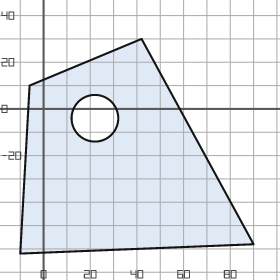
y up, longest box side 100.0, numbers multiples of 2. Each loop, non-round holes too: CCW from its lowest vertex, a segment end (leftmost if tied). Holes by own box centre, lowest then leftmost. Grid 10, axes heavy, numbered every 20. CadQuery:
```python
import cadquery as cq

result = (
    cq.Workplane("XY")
    .moveTo(-10.0, -62.0)
    .lineTo(90.0, -58.0)
    .lineTo(42.0, 30.0)
    .lineTo(-6.0, 10.0)
    .close()
    .moveTo(22.0, -4.0)
    .circle(10.0)
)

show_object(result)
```